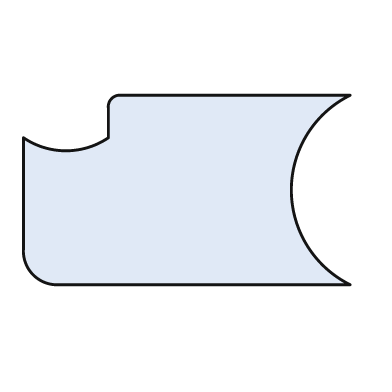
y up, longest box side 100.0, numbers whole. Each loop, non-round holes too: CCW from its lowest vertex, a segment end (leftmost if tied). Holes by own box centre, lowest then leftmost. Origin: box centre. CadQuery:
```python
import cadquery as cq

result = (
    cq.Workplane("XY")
    .moveTo(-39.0, -29.0)
    .lineTo(50.0, -29.0)
    .threePointArc((32.0, 0.0), (50.0, 29.0))
    .lineTo(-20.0, 29.0)
    .threePointArc((-23.0, 28.0), (-24.0, 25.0))
    .lineTo(-24.0, 16.0)
    .threePointArc((-37.0, 12.0), (-50.0, 16.0))
    .lineTo(-50.0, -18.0)
    .threePointArc((-47.0, -26.0), (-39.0, -29.0))
    .close()
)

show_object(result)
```